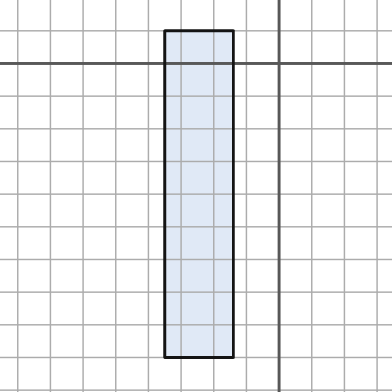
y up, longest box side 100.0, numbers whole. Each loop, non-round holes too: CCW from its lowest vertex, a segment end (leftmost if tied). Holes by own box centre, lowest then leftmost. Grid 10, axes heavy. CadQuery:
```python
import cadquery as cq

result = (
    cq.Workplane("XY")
    .moveTo(-35.0, -90.0)
    .lineTo(-14.0, -90.0)
    .lineTo(-14.0, 10.0)
    .lineTo(-35.0, 10.0)
    .close()
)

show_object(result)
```